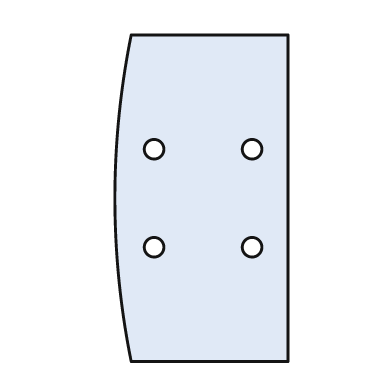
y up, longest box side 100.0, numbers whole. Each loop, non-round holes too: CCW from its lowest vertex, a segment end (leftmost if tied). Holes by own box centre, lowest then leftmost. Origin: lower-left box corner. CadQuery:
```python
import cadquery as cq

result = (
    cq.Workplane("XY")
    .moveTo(5.0, 0.0)
    .lineTo(53.0, 0.0)
    .lineTo(53.0, 100.0)
    .lineTo(5.0, 100.0)
    .threePointArc((0.0, 50.0), (5.0, 0.0))
    .close()
    .moveTo(12.0, 35.0)
    .circle(3.0)
    .moveTo(42.0, 35.0)
    .circle(3.0)
    .moveTo(12.0, 65.0)
    .circle(3.0)
    .moveTo(42.0, 65.0)
    .circle(3.0)
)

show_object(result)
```